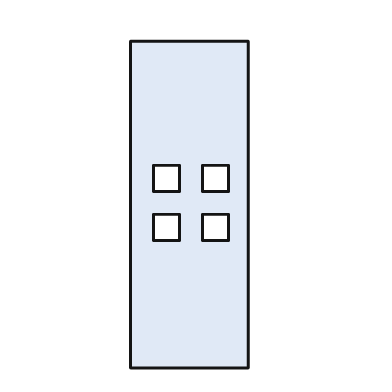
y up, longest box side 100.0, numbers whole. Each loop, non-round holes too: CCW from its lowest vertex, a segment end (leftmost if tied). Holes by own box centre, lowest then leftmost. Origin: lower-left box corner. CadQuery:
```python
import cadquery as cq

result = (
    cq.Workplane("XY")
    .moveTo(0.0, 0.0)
    .lineTo(36.0, 0.0)
    .lineTo(36.0, 100.0)
    .lineTo(0.0, 100.0)
    .close()
    .moveTo(7.0, 39.0)
    .lineTo(15.0, 39.0)
    .lineTo(15.0, 47.0)
    .lineTo(7.0, 47.0)
    .close()
    .moveTo(22.0, 39.0)
    .lineTo(30.0, 39.0)
    .lineTo(30.0, 47.0)
    .lineTo(22.0, 47.0)
    .close()
    .moveTo(7.0, 54.0)
    .lineTo(15.0, 54.0)
    .lineTo(15.0, 62.0)
    .lineTo(7.0, 62.0)
    .close()
    .moveTo(22.0, 54.0)
    .lineTo(30.0, 54.0)
    .lineTo(30.0, 62.0)
    .lineTo(22.0, 62.0)
    .close()
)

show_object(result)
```